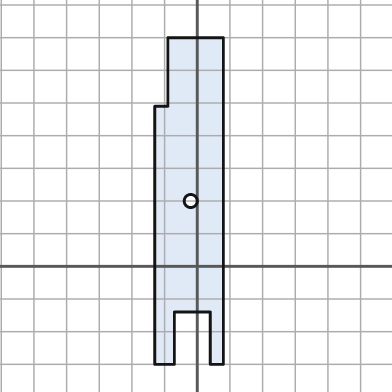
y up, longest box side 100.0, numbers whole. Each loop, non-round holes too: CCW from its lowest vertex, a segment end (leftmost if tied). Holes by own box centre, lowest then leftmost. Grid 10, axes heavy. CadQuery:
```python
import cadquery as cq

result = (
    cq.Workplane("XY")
    .moveTo(-13.0, -30.0)
    .lineTo(-7.0, -30.0)
    .lineTo(-7.0, -14.0)
    .lineTo(4.0, -14.0)
    .lineTo(4.0, -30.0)
    .lineTo(8.0, -30.0)
    .lineTo(8.0, 70.0)
    .lineTo(-9.0, 70.0)
    .lineTo(-9.0, 49.0)
    .lineTo(-13.0, 49.0)
    .close()
    .moveTo(-2.0, 20.0)
    .circle(2.0)
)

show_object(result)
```